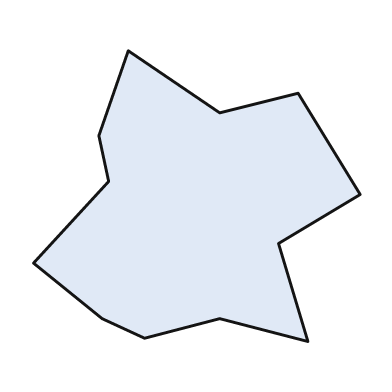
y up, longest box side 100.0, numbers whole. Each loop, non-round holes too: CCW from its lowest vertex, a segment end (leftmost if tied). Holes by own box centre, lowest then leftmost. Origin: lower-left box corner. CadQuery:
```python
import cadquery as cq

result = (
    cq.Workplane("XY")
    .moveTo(84.0, 0.0)
    .lineTo(75.0, 30.0)
    .lineTo(100.0, 45.0)
    .lineTo(81.0, 76.0)
    .lineTo(57.0, 70.0)
    .lineTo(29.0, 89.0)
    .lineTo(20.0, 63.0)
    .lineTo(23.0, 49.0)
    .lineTo(0.0, 24.0)
    .lineTo(21.0, 7.0)
    .lineTo(34.0, 1.0)
    .lineTo(57.0, 7.0)
    .close()
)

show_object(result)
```